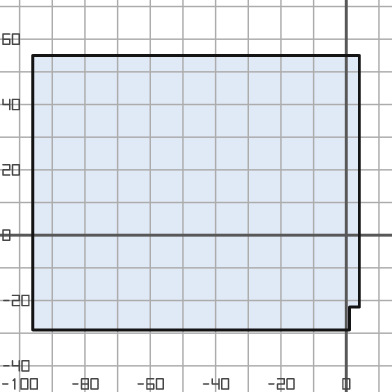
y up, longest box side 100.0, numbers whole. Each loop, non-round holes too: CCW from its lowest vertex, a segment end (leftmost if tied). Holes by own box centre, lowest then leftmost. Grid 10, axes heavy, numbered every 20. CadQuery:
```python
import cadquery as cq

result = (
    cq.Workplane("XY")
    .moveTo(-96.0, -29.0)
    .lineTo(1.0, -29.0)
    .lineTo(1.0, -22.0)
    .lineTo(4.0, -22.0)
    .lineTo(4.0, 55.0)
    .lineTo(-96.0, 55.0)
    .close()
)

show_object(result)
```